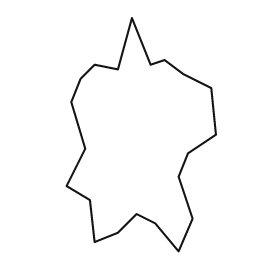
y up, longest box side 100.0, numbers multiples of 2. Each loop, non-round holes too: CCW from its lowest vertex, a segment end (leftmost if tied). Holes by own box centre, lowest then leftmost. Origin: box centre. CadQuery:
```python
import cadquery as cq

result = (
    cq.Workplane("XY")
    .moveTo(16.0, -50.0)
    .lineTo(22.0, -36.0)
    .lineTo(16.0, -18.0)
    .lineTo(20.0, -8.0)
    .lineTo(32.0, 0.0)
    .lineTo(30.0, 20.0)
    .lineTo(18.0, 26.0)
    .lineTo(10.0, 32.0)
    .lineTo(4.0, 30.0)
    .lineTo(-4.0, 50.0)
    .lineTo(-10.0, 28.0)
    .lineTo(-20.0, 30.0)
    .lineTo(-26.0, 24.0)
    .lineTo(-30.0, 14.0)
    .lineTo(-24.0, -6.0)
    .lineTo(-32.0, -22.0)
    .lineTo(-22.0, -28.0)
    .lineTo(-20.0, -46.0)
    .lineTo(-10.0, -42.0)
    .lineTo(-2.0, -34.0)
    .lineTo(6.0, -38.0)
    .close()
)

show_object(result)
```